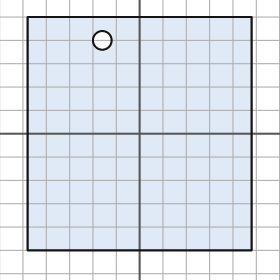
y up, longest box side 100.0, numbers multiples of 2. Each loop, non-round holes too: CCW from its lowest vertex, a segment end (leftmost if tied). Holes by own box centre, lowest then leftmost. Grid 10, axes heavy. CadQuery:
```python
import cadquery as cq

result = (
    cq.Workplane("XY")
    .moveTo(-48.0, -50.0)
    .lineTo(48.0, -50.0)
    .lineTo(48.0, 50.0)
    .lineTo(-48.0, 50.0)
    .close()
    .moveTo(-16.0, 40.0)
    .circle(4.0)
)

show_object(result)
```